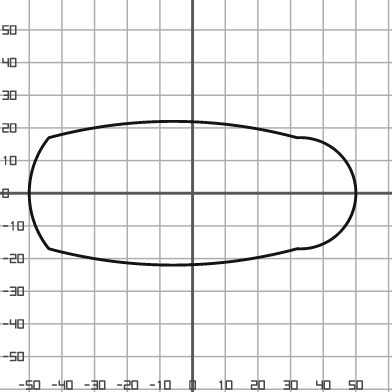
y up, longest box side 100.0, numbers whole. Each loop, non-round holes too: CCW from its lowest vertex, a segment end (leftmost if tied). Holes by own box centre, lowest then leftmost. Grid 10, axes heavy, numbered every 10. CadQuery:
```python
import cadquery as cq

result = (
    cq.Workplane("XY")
    .moveTo(-44.0, -17.0)
    .threePointArc((-6.0, -22.0), (32.0, -17.0))
    .threePointArc((50.0, 0.0), (32.0, 17.0))
    .threePointArc((-6.0, 22.0), (-44.0, 17.0))
    .threePointArc((-50.0, 0.0), (-44.0, -17.0))
    .close()
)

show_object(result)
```